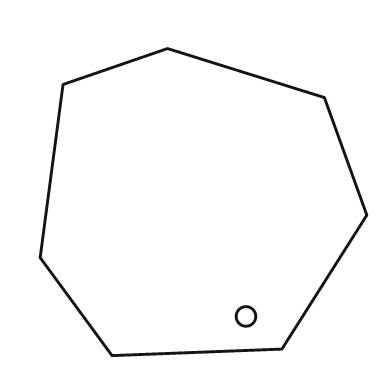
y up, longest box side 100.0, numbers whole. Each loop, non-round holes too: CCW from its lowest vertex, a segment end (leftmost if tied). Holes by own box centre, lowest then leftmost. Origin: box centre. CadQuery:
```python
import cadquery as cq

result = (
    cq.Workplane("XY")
    .moveTo(-28.0, -47.0)
    .lineTo(24.0, -45.0)
    .lineTo(50.0, -4.0)
    .lineTo(37.0, 32.0)
    .lineTo(-11.0, 47.0)
    .lineTo(-43.0, 36.0)
    .lineTo(-50.0, -17.0)
    .close()
    .moveTo(13.0, -35.0)
    .circle(3.0)
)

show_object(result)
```